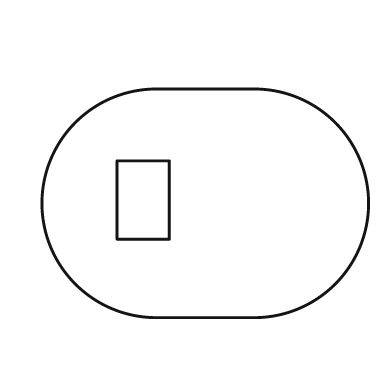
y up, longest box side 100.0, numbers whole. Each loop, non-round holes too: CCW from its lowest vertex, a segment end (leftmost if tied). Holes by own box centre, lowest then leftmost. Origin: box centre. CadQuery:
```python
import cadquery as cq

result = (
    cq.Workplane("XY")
    .moveTo(-15.0, -35.0)
    .lineTo(15.0, -35.0)
    .threePointArc((50.0, 0.0), (15.0, 35.0))
    .lineTo(-15.0, 35.0)
    .threePointArc((-50.0, 0.0), (-15.0, -35.0))
    .close()
    .moveTo(-27.0, -11.0)
    .lineTo(-11.0, -11.0)
    .lineTo(-11.0, 13.0)
    .lineTo(-27.0, 13.0)
    .close()
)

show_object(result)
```